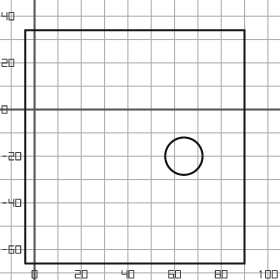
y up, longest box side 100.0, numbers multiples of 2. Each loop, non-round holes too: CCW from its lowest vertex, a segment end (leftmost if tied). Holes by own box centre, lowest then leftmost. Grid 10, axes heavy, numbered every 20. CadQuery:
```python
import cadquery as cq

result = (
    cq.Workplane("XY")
    .moveTo(-4.0, -66.0)
    .lineTo(90.0, -66.0)
    .lineTo(90.0, 34.0)
    .lineTo(-4.0, 34.0)
    .close()
    .moveTo(64.0, -20.0)
    .circle(8.0)
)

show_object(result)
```